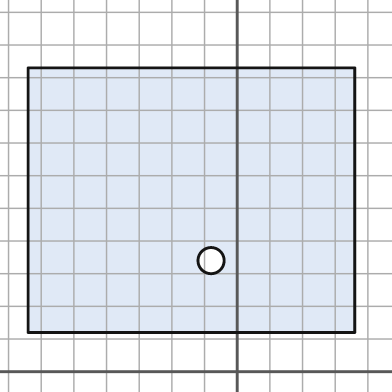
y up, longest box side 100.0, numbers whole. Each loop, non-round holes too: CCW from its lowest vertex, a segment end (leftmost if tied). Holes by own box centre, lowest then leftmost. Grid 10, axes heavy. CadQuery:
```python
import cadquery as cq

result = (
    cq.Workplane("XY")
    .moveTo(-64.0, 12.0)
    .lineTo(36.0, 12.0)
    .lineTo(36.0, 93.0)
    .lineTo(-64.0, 93.0)
    .close()
    .moveTo(-8.0, 34.0)
    .circle(4.0)
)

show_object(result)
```